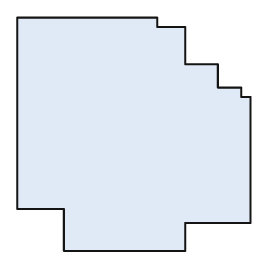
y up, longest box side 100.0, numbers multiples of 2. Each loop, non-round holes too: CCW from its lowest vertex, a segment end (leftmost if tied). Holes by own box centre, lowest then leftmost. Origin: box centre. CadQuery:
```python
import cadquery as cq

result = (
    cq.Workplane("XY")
    .moveTo(-30.0, -50.0)
    .lineTo(22.0, -50.0)
    .lineTo(22.0, -38.0)
    .lineTo(50.0, -38.0)
    .lineTo(50.0, 16.0)
    .lineTo(46.0, 16.0)
    .lineTo(46.0, 20.0)
    .lineTo(36.0, 20.0)
    .lineTo(36.0, 30.0)
    .lineTo(22.0, 30.0)
    .lineTo(22.0, 46.0)
    .lineTo(10.0, 46.0)
    .lineTo(10.0, 50.0)
    .lineTo(-50.0, 50.0)
    .lineTo(-50.0, -32.0)
    .lineTo(-30.0, -32.0)
    .close()
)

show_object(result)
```